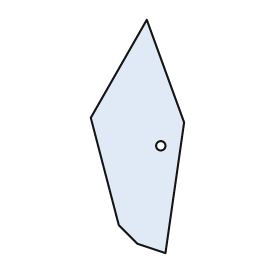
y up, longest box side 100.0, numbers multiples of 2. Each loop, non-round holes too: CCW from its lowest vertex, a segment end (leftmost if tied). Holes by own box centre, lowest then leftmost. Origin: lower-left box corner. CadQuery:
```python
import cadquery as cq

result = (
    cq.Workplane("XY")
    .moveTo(32.0, 0.0)
    .lineTo(40.0, 56.0)
    .lineTo(24.0, 100.0)
    .lineTo(0.0, 58.0)
    .lineTo(12.0, 12.0)
    .lineTo(20.0, 4.0)
    .close()
    .moveTo(30.0, 46.0)
    .circle(2.0)
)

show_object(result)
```